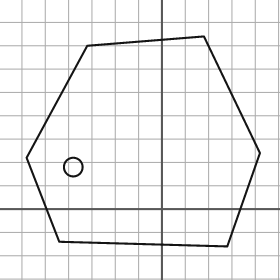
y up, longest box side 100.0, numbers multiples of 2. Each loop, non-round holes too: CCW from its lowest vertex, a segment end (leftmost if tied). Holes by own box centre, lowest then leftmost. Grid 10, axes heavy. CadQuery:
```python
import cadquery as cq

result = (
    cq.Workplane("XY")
    .moveTo(28.0, -16.0)
    .lineTo(42.0, 24.0)
    .lineTo(18.0, 74.0)
    .lineTo(-32.0, 70.0)
    .lineTo(-58.0, 22.0)
    .lineTo(-44.0, -14.0)
    .close()
    .moveTo(-38.0, 18.0)
    .circle(4.0)
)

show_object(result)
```